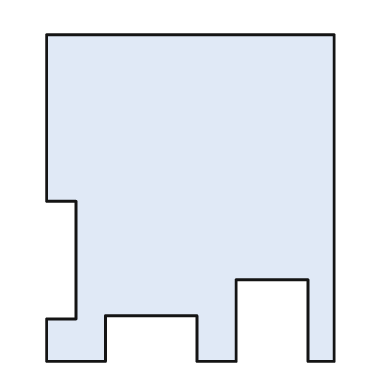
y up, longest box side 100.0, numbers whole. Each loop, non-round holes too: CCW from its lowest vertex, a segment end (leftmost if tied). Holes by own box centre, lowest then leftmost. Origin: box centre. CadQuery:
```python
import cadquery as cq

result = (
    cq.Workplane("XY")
    .moveTo(-44.0, -50.0)
    .lineTo(-26.0, -50.0)
    .lineTo(-26.0, -36.0)
    .lineTo(2.0, -36.0)
    .lineTo(2.0, -50.0)
    .lineTo(14.0, -50.0)
    .lineTo(14.0, -25.0)
    .lineTo(36.0, -25.0)
    .lineTo(36.0, -50.0)
    .lineTo(44.0, -50.0)
    .lineTo(44.0, 50.0)
    .lineTo(-44.0, 50.0)
    .lineTo(-44.0, -1.0)
    .lineTo(-35.0, -1.0)
    .lineTo(-35.0, -37.0)
    .lineTo(-44.0, -37.0)
    .close()
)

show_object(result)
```